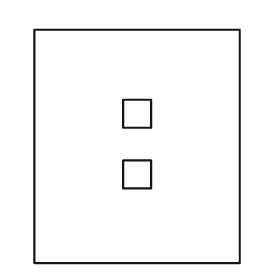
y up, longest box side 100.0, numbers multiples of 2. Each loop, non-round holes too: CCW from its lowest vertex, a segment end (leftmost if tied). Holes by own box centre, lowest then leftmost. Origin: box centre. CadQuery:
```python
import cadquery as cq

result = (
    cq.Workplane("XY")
    .moveTo(-44.0, -50.0)
    .lineTo(44.0, -50.0)
    .lineTo(44.0, 50.0)
    .lineTo(-44.0, 50.0)
    .close()
    .moveTo(-6.0, -18.0)
    .lineTo(6.0, -18.0)
    .lineTo(6.0, -6.0)
    .lineTo(-6.0, -6.0)
    .close()
    .moveTo(-6.0, 8.0)
    .lineTo(6.0, 8.0)
    .lineTo(6.0, 20.0)
    .lineTo(-6.0, 20.0)
    .close()
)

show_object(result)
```